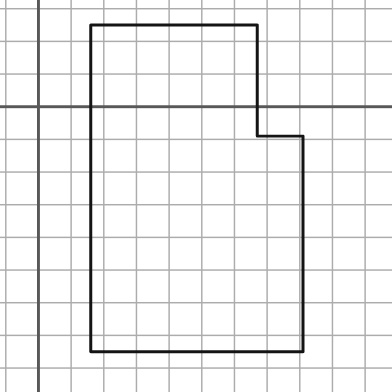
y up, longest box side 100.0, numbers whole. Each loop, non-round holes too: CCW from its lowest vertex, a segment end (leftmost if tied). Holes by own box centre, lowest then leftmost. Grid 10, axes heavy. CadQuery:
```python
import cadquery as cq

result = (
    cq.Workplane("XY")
    .moveTo(16.0, -75.0)
    .lineTo(81.0, -75.0)
    .lineTo(81.0, -9.0)
    .lineTo(67.0, -9.0)
    .lineTo(67.0, 25.0)
    .lineTo(16.0, 25.0)
    .close()
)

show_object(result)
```